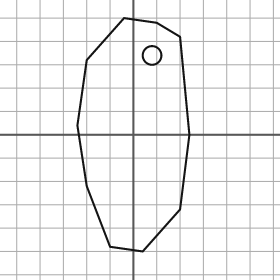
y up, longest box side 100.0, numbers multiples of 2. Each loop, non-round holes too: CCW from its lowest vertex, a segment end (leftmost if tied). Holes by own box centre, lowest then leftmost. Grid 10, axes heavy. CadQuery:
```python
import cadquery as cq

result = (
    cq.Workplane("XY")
    .moveTo(4.0, -50.0)
    .lineTo(20.0, -32.0)
    .lineTo(24.0, 0.0)
    .lineTo(20.0, 42.0)
    .lineTo(10.0, 48.0)
    .lineTo(-4.0, 50.0)
    .lineTo(-20.0, 32.0)
    .lineTo(-24.0, 4.0)
    .lineTo(-20.0, -22.0)
    .lineTo(-10.0, -48.0)
    .close()
    .moveTo(8.0, 34.0)
    .circle(4.0)
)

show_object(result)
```